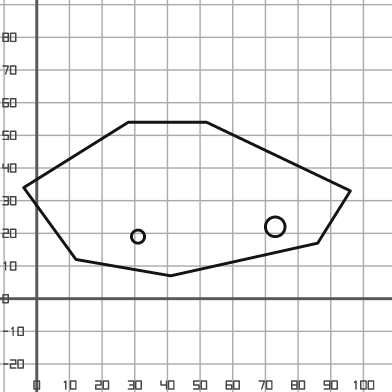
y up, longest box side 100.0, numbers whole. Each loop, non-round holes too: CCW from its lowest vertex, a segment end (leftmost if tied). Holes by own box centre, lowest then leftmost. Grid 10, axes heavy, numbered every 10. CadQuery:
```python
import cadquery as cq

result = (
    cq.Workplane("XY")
    .moveTo(41.0, 7.0)
    .lineTo(86.0, 17.0)
    .lineTo(96.0, 33.0)
    .lineTo(52.0, 54.0)
    .lineTo(28.0, 54.0)
    .lineTo(-4.0, 34.0)
    .lineTo(12.0, 12.0)
    .close()
    .moveTo(31.0, 19.0)
    .circle(2.0)
    .moveTo(73.0, 22.0)
    .circle(3.0)
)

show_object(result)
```